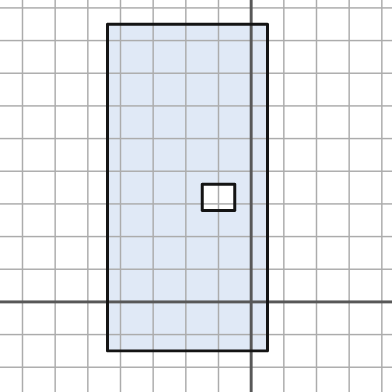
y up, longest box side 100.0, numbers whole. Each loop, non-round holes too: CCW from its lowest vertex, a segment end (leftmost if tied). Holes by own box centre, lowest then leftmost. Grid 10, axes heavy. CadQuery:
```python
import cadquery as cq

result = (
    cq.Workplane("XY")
    .moveTo(-44.0, -15.0)
    .lineTo(5.0, -15.0)
    .lineTo(5.0, 85.0)
    .lineTo(-44.0, 85.0)
    .close()
    .moveTo(-15.0, 28.0)
    .lineTo(-5.0, 28.0)
    .lineTo(-5.0, 36.0)
    .lineTo(-15.0, 36.0)
    .close()
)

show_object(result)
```